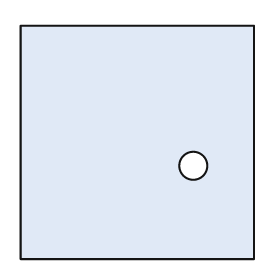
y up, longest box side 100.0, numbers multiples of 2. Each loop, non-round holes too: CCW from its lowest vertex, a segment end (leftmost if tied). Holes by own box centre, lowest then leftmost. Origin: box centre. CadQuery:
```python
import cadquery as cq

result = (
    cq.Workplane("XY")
    .moveTo(-50.0, -50.0)
    .lineTo(50.0, -50.0)
    .lineTo(50.0, 50.0)
    .lineTo(-50.0, 50.0)
    .close()
    .moveTo(24.0, -10.0)
    .circle(6.0)
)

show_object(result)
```